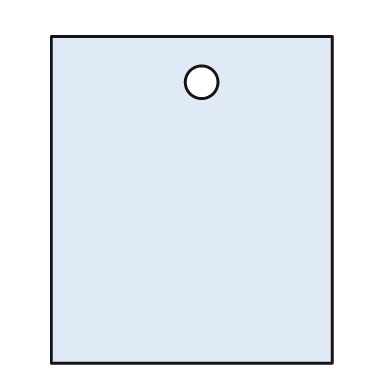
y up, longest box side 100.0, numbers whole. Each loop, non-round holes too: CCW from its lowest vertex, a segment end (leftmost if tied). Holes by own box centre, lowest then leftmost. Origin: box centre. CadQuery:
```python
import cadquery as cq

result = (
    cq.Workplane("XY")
    .moveTo(-43.0, -50.0)
    .lineTo(43.0, -50.0)
    .lineTo(43.0, 50.0)
    .lineTo(-43.0, 50.0)
    .close()
    .moveTo(3.0, 36.0)
    .circle(5.0)
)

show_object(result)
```